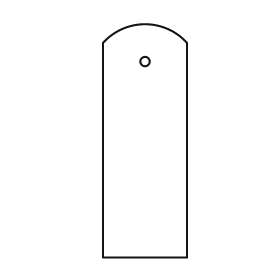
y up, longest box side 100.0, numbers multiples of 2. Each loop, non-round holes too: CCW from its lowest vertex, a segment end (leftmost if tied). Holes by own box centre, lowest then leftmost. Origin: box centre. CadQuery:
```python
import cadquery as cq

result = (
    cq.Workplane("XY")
    .moveTo(-18.0, -50.0)
    .lineTo(18.0, -50.0)
    .lineTo(18.0, 42.0)
    .threePointArc((0.0, 50.0), (-18.0, 42.0))
    .close()
    .moveTo(0.0, 34.0)
    .circle(2.0)
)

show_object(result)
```